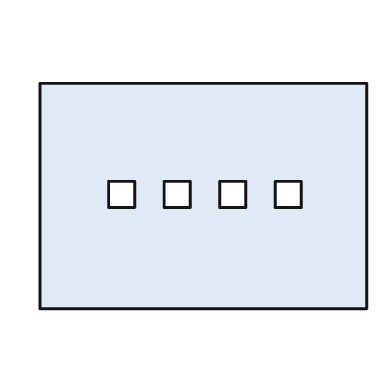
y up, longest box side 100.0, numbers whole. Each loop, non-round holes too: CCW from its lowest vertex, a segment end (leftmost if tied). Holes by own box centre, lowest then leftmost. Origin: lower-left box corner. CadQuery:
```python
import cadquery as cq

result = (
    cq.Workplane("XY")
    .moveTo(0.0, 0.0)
    .lineTo(100.0, 0.0)
    .lineTo(100.0, 69.0)
    .lineTo(0.0, 69.0)
    .close()
    .moveTo(21.0, 31.0)
    .lineTo(29.0, 31.0)
    .lineTo(29.0, 39.0)
    .lineTo(21.0, 39.0)
    .close()
    .moveTo(38.0, 31.0)
    .lineTo(46.0, 31.0)
    .lineTo(46.0, 39.0)
    .lineTo(38.0, 39.0)
    .close()
    .moveTo(55.0, 31.0)
    .lineTo(63.0, 31.0)
    .lineTo(63.0, 39.0)
    .lineTo(55.0, 39.0)
    .close()
    .moveTo(72.0, 31.0)
    .lineTo(80.0, 31.0)
    .lineTo(80.0, 39.0)
    .lineTo(72.0, 39.0)
    .close()
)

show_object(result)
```